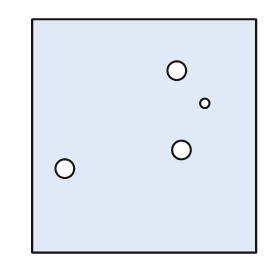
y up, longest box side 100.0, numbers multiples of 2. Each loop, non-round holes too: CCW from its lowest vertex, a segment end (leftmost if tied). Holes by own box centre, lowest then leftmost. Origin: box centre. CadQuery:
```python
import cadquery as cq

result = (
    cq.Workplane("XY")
    .moveTo(-48.0, -50.0)
    .lineTo(48.0, -50.0)
    .lineTo(48.0, 50.0)
    .lineTo(-48.0, 50.0)
    .close()
    .moveTo(-34.0, -14.0)
    .circle(4.0)
    .moveTo(16.0, -6.0)
    .circle(4.0)
    .moveTo(26.0, 14.0)
    .circle(2.0)
    .moveTo(14.0, 28.0)
    .circle(4.0)
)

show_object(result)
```